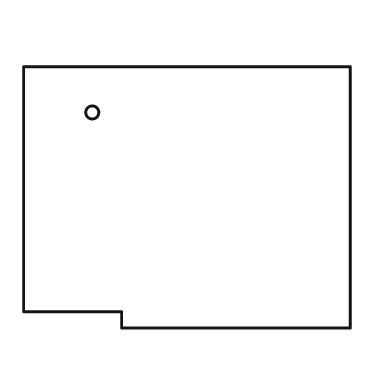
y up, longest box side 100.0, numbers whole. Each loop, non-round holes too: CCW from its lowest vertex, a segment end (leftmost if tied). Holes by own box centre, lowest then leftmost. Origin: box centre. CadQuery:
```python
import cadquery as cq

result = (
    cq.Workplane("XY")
    .moveTo(-20.0, -40.0)
    .lineTo(50.0, -40.0)
    .lineTo(50.0, 40.0)
    .lineTo(-50.0, 40.0)
    .lineTo(-50.0, -35.0)
    .lineTo(-20.0, -35.0)
    .close()
    .moveTo(-29.0, 26.0)
    .circle(2.0)
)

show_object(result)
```